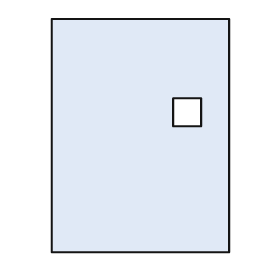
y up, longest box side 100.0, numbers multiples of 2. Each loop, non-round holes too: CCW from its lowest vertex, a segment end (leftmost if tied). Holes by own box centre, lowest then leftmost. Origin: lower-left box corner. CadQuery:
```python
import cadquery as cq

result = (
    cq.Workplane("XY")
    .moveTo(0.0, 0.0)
    .lineTo(76.0, 0.0)
    .lineTo(76.0, 100.0)
    .lineTo(0.0, 100.0)
    .close()
    .moveTo(52.0, 54.0)
    .lineTo(64.0, 54.0)
    .lineTo(64.0, 66.0)
    .lineTo(52.0, 66.0)
    .close()
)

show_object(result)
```